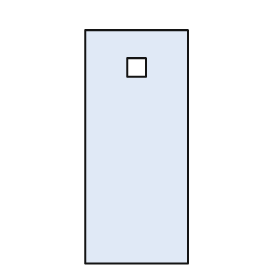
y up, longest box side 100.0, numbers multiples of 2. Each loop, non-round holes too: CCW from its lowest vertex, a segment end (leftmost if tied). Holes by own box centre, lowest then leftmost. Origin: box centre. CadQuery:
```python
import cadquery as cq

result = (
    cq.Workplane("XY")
    .moveTo(-22.0, -50.0)
    .lineTo(22.0, -50.0)
    .lineTo(22.0, 50.0)
    .lineTo(-22.0, 50.0)
    .close()
    .moveTo(-4.0, 30.0)
    .lineTo(4.0, 30.0)
    .lineTo(4.0, 38.0)
    .lineTo(-4.0, 38.0)
    .close()
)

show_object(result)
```